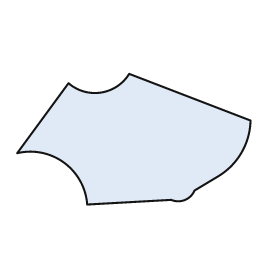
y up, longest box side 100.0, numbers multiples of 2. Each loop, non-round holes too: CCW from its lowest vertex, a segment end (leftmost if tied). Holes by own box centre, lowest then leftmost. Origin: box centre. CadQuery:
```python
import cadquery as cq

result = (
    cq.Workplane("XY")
    .moveTo(-20.0, -28.0)
    .lineTo(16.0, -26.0)
    .threePointArc((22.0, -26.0), (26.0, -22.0))
    .lineTo(36.0, -16.0)
    .threePointArc((46.0, -6.0), (50.0, 8.0))
    .lineTo(-2.0, 28.0)
    .threePointArc((-14.0, 20.0), (-28.0, 24.0))
    .lineTo(-50.0, -6.0)
    .threePointArc((-30.0, -10.0), (-20.0, -28.0))
    .close()
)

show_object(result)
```